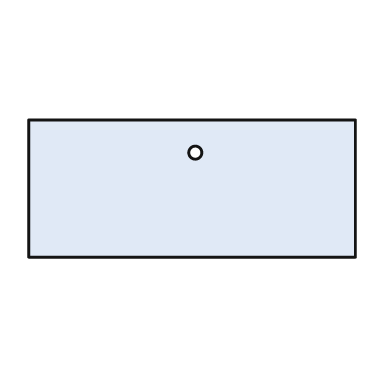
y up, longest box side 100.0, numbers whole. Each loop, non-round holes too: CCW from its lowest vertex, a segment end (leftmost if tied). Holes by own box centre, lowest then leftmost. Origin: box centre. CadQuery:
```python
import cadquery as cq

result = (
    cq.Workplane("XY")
    .moveTo(-50.0, -21.0)
    .lineTo(50.0, -21.0)
    .lineTo(50.0, 21.0)
    .lineTo(-50.0, 21.0)
    .close()
    .moveTo(1.0, 11.0)
    .circle(2.0)
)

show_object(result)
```